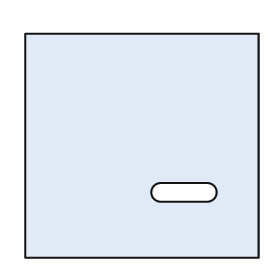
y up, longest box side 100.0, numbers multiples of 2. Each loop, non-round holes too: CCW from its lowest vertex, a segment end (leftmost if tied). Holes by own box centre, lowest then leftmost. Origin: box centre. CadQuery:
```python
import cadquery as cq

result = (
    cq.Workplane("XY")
    .moveTo(-50.0, -48.0)
    .lineTo(50.0, -48.0)
    .lineTo(50.0, 48.0)
    .lineTo(-50.0, 48.0)
    .close()
    .moveTo(8.0, -24.0)
    .lineTo(28.0, -24.0)
    .threePointArc((32.0, -20.0), (28.0, -16.0))
    .lineTo(8.0, -16.0)
    .threePointArc((4.0, -20.0), (8.0, -24.0))
    .close()
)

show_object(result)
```